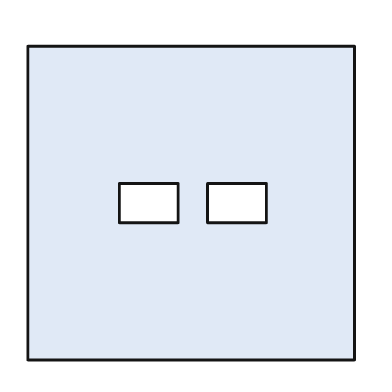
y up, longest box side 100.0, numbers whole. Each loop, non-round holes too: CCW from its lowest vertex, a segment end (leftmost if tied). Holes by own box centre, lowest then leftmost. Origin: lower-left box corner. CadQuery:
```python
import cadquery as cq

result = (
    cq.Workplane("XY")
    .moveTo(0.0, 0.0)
    .lineTo(100.0, 0.0)
    .lineTo(100.0, 96.0)
    .lineTo(0.0, 96.0)
    .close()
    .moveTo(28.0, 42.0)
    .lineTo(46.0, 42.0)
    .lineTo(46.0, 54.0)
    .lineTo(28.0, 54.0)
    .close()
    .moveTo(55.0, 42.0)
    .lineTo(73.0, 42.0)
    .lineTo(73.0, 54.0)
    .lineTo(55.0, 54.0)
    .close()
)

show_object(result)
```